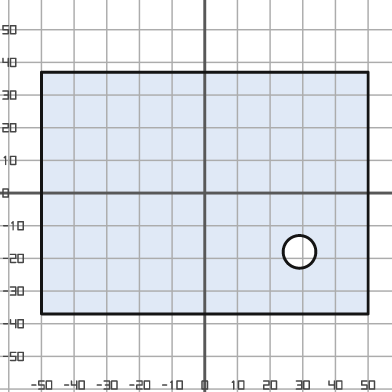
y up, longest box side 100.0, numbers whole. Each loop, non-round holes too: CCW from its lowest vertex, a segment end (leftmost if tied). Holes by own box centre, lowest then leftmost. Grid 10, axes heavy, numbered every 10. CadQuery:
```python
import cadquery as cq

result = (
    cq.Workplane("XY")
    .moveTo(-50.0, -37.0)
    .lineTo(50.0, -37.0)
    .lineTo(50.0, 37.0)
    .lineTo(-50.0, 37.0)
    .close()
    .moveTo(29.0, -18.0)
    .circle(5.0)
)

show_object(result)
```